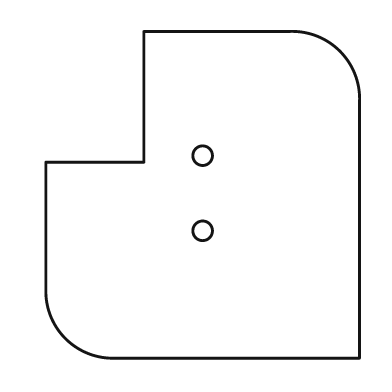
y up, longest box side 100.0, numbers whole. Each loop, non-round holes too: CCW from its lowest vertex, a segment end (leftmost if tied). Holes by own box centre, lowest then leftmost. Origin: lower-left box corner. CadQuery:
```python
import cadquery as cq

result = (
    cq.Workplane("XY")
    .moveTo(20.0, 0.0)
    .lineTo(96.0, 0.0)
    .lineTo(96.0, 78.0)
    .threePointArc((90.0, 94.0), (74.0, 100.0))
    .lineTo(30.0, 100.0)
    .lineTo(30.0, 60.0)
    .lineTo(0.0, 60.0)
    .lineTo(0.0, 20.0)
    .threePointArc((6.0, 6.0), (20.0, 0.0))
    .close()
    .moveTo(48.0, 39.0)
    .circle(3.0)
    .moveTo(48.0, 62.0)
    .circle(3.0)
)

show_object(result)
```